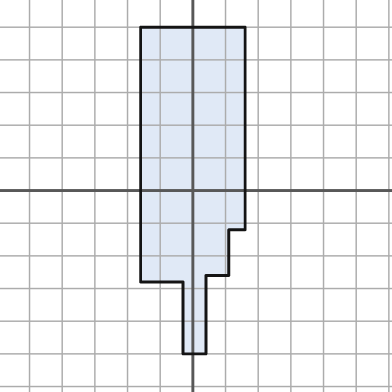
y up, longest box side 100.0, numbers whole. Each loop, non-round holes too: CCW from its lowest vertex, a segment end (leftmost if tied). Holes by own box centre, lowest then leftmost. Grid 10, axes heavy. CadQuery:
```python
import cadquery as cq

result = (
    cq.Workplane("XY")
    .moveTo(-3.0, -50.0)
    .lineTo(4.0, -50.0)
    .lineTo(4.0, -26.0)
    .lineTo(11.0, -26.0)
    .lineTo(11.0, -12.0)
    .lineTo(16.0, -12.0)
    .lineTo(16.0, 50.0)
    .lineTo(-16.0, 50.0)
    .lineTo(-16.0, -28.0)
    .lineTo(-3.0, -28.0)
    .close()
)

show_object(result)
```